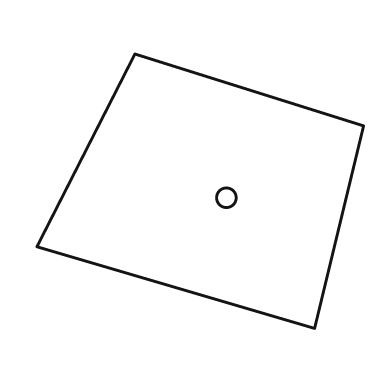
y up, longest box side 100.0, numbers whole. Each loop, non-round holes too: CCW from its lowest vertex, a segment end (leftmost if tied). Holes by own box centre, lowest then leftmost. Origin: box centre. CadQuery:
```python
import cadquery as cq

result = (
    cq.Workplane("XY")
    .moveTo(35.0, -42.0)
    .lineTo(50.0, 20.0)
    .lineTo(-20.0, 42.0)
    .lineTo(-50.0, -17.0)
    .close()
    .moveTo(8.0, -2.0)
    .circle(3.0)
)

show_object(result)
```